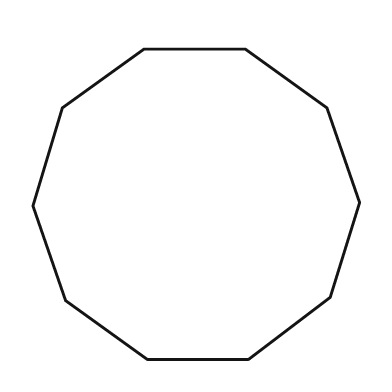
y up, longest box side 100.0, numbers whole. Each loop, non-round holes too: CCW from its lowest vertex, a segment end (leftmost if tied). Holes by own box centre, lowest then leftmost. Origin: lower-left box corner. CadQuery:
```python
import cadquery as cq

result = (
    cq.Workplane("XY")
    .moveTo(35.0, 0.0)
    .lineTo(66.0, 0.0)
    .lineTo(91.0, 19.0)
    .lineTo(100.0, 48.0)
    .lineTo(90.0, 77.0)
    .lineTo(65.0, 95.0)
    .lineTo(34.0, 95.0)
    .lineTo(9.0, 77.0)
    .lineTo(0.0, 47.0)
    .lineTo(10.0, 18.0)
    .close()
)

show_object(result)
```